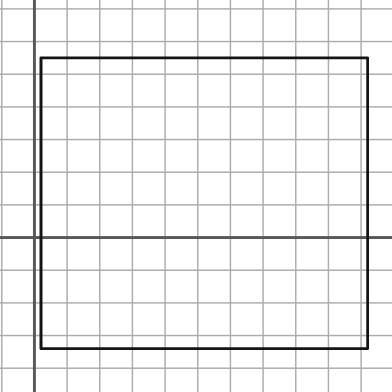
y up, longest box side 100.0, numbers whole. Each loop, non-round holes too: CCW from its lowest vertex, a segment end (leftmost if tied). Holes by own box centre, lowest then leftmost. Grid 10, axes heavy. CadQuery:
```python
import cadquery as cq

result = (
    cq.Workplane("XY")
    .moveTo(2.0, -34.0)
    .lineTo(102.0, -34.0)
    .lineTo(102.0, 55.0)
    .lineTo(2.0, 55.0)
    .close()
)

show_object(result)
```